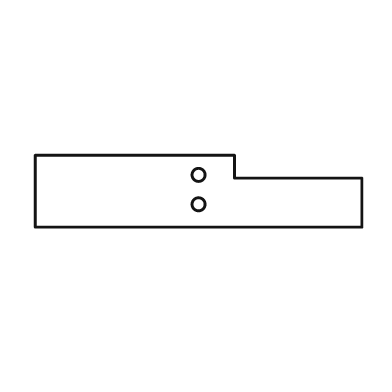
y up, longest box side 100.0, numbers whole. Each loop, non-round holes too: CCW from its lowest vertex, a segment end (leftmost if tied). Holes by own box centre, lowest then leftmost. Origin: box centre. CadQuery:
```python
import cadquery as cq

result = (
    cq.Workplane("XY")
    .moveTo(-50.0, -11.0)
    .lineTo(50.0, -11.0)
    .lineTo(50.0, 4.0)
    .lineTo(11.0, 4.0)
    .lineTo(11.0, 11.0)
    .lineTo(-50.0, 11.0)
    .close()
    .moveTo(0.0, -4.0)
    .circle(2.0)
    .moveTo(0.0, 5.0)
    .circle(2.0)
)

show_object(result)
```